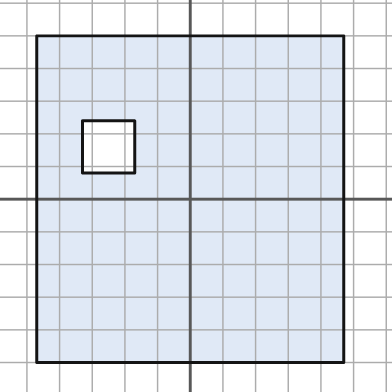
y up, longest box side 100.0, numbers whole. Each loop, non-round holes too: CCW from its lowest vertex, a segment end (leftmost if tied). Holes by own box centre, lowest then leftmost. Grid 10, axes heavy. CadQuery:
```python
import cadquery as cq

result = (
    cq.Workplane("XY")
    .moveTo(-47.0, -50.0)
    .lineTo(47.0, -50.0)
    .lineTo(47.0, 50.0)
    .lineTo(-47.0, 50.0)
    .close()
    .moveTo(-33.0, 8.0)
    .lineTo(-17.0, 8.0)
    .lineTo(-17.0, 24.0)
    .lineTo(-33.0, 24.0)
    .close()
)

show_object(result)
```